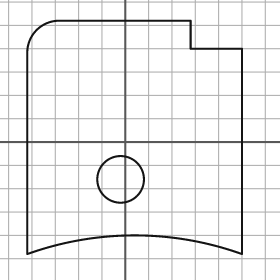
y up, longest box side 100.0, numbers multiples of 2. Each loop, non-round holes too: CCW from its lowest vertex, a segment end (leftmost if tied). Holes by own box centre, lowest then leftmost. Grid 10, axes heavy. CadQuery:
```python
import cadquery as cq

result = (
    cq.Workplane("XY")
    .moveTo(-42.0, -48.0)
    .threePointArc((4.0, -40.0), (50.0, -48.0))
    .lineTo(50.0, 40.0)
    .lineTo(28.0, 40.0)
    .lineTo(28.0, 52.0)
    .lineTo(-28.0, 52.0)
    .threePointArc((-38.0, 48.0), (-42.0, 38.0))
    .close()
    .moveTo(-2.0, -16.0)
    .circle(10.0)
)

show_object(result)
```